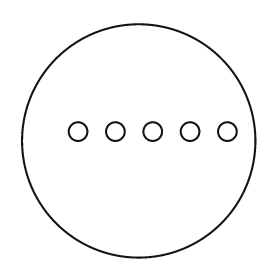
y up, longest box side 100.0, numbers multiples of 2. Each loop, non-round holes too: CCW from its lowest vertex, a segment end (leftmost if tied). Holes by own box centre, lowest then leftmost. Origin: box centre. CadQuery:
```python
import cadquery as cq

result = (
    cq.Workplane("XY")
    .moveTo(0.0, 0.0)
    .circle(50.0)
    .moveTo(-26.0, 4.0)
    .circle(4.0)
    .moveTo(-10.0, 4.0)
    .circle(4.0)
    .moveTo(6.0, 4.0)
    .circle(4.0)
    .moveTo(22.0, 4.0)
    .circle(4.0)
    .moveTo(38.0, 4.0)
    .circle(4.0)
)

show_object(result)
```